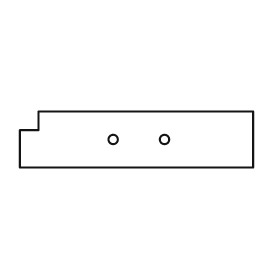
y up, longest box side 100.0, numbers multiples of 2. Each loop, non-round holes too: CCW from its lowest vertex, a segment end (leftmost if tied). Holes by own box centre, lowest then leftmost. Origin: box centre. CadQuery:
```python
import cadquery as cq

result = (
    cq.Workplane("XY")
    .moveTo(-50.0, -12.0)
    .lineTo(50.0, -12.0)
    .lineTo(50.0, 12.0)
    .lineTo(-42.0, 12.0)
    .lineTo(-42.0, 4.0)
    .lineTo(-50.0, 4.0)
    .close()
    .moveTo(-10.0, 0.0)
    .circle(2.0)
    .moveTo(12.0, 0.0)
    .circle(2.0)
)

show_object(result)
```